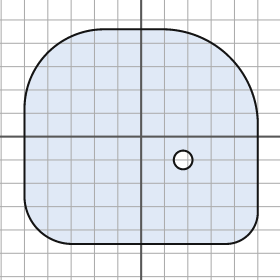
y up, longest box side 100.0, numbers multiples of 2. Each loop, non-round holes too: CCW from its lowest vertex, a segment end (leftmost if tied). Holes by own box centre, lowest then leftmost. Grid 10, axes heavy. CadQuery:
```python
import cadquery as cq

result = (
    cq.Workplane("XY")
    .moveTo(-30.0, -46.0)
    .lineTo(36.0, -46.0)
    .threePointArc((46.0, -42.0), (50.0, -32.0))
    .lineTo(50.0, 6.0)
    .threePointArc((38.0, 34.0), (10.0, 46.0))
    .lineTo(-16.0, 46.0)
    .threePointArc((-40.0, 36.0), (-50.0, 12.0))
    .lineTo(-50.0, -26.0)
    .threePointArc((-44.0, -40.0), (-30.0, -46.0))
    .close()
    .moveTo(18.0, -10.0)
    .circle(4.0)
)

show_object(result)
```